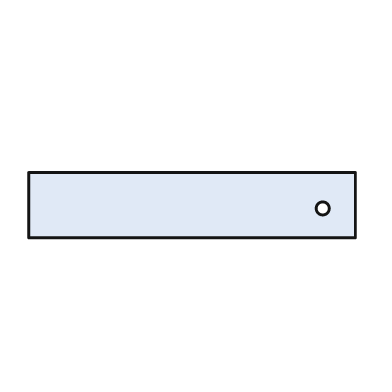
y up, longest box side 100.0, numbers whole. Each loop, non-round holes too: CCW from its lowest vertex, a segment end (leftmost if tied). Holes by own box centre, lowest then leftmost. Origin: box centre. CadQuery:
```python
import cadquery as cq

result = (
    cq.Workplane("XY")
    .moveTo(-50.0, -10.0)
    .lineTo(50.0, -10.0)
    .lineTo(50.0, 10.0)
    .lineTo(-50.0, 10.0)
    .close()
    .moveTo(40.0, -1.0)
    .circle(2.0)
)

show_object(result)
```